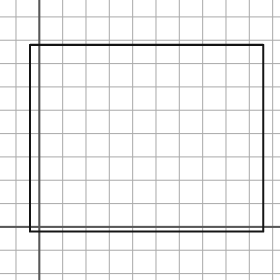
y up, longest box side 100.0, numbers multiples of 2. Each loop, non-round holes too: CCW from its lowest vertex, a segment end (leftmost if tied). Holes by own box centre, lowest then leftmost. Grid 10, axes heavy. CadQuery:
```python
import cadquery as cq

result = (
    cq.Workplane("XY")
    .moveTo(-4.0, -2.0)
    .lineTo(96.0, -2.0)
    .lineTo(96.0, 78.0)
    .lineTo(-4.0, 78.0)
    .close()
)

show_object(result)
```